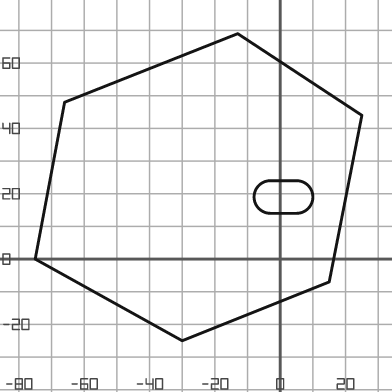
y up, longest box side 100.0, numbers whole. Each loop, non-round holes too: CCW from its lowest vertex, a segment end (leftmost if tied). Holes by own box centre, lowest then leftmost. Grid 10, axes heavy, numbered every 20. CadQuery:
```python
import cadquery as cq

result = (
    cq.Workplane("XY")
    .moveTo(-30.0, -25.0)
    .lineTo(15.0, -7.0)
    .lineTo(25.0, 44.0)
    .lineTo(-13.0, 69.0)
    .lineTo(-66.0, 48.0)
    .lineTo(-75.0, 0.0)
    .close()
    .moveTo(-3.0, 14.0)
    .lineTo(5.0, 14.0)
    .threePointArc((10.0, 19.0), (5.0, 24.0))
    .lineTo(-3.0, 24.0)
    .threePointArc((-8.0, 19.0), (-3.0, 14.0))
    .close()
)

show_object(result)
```